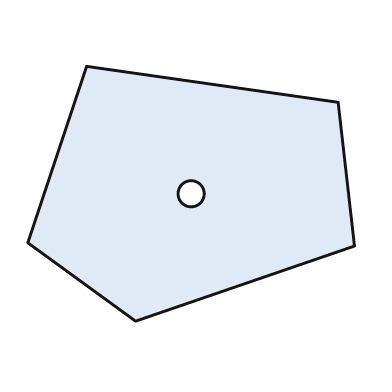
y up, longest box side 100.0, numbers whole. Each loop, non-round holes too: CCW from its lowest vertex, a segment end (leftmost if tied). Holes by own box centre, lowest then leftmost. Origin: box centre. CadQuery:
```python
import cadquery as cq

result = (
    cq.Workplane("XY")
    .moveTo(-17.0, -39.0)
    .lineTo(50.0, -16.0)
    .lineTo(45.0, 28.0)
    .lineTo(-32.0, 39.0)
    .lineTo(-50.0, -15.0)
    .close()
    .moveTo(0.0, 0.0)
    .circle(4.0)
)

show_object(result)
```